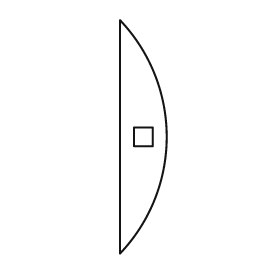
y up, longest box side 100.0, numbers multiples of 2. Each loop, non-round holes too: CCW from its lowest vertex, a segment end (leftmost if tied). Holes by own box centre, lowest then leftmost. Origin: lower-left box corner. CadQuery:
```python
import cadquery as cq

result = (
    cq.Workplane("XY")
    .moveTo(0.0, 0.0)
    .threePointArc((20.0, 50.0), (0.0, 100.0))
    .close()
    .moveTo(6.0, 46.0)
    .lineTo(14.0, 46.0)
    .lineTo(14.0, 54.0)
    .lineTo(6.0, 54.0)
    .close()
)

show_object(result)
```